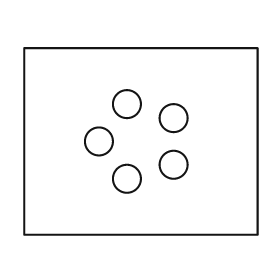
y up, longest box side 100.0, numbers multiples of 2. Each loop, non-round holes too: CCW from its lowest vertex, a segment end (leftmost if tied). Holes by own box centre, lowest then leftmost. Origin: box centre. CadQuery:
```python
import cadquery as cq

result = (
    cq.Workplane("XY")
    .moveTo(-50.0, -40.0)
    .lineTo(50.0, -40.0)
    .lineTo(50.0, 40.0)
    .lineTo(-50.0, 40.0)
    .close()
    .moveTo(-6.0, -16.0)
    .circle(6.0)
    .moveTo(14.0, -10.0)
    .circle(6.0)
    .moveTo(-18.0, 0.0)
    .circle(6.0)
    .moveTo(14.0, 10.0)
    .circle(6.0)
    .moveTo(-6.0, 16.0)
    .circle(6.0)
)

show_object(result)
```